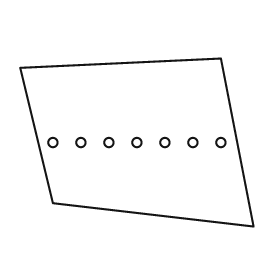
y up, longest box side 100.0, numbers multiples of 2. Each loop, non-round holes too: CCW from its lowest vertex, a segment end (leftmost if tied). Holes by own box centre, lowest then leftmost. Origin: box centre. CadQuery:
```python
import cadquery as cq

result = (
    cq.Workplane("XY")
    .moveTo(50.0, -36.0)
    .lineTo(36.0, 36.0)
    .lineTo(-50.0, 32.0)
    .lineTo(-36.0, -26.0)
    .close()
    .moveTo(-36.0, 0.0)
    .circle(2.0)
    .moveTo(-24.0, 0.0)
    .circle(2.0)
    .moveTo(-12.0, 0.0)
    .circle(2.0)
    .moveTo(0.0, 0.0)
    .circle(2.0)
    .moveTo(12.0, 0.0)
    .circle(2.0)
    .moveTo(24.0, 0.0)
    .circle(2.0)
    .moveTo(36.0, 0.0)
    .circle(2.0)
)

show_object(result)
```